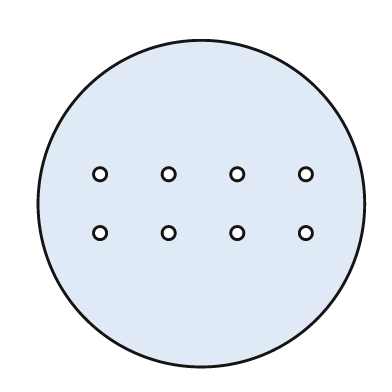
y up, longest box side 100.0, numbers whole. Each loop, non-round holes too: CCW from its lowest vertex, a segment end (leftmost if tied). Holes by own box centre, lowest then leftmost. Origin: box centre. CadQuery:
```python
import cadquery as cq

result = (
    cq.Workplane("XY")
    .moveTo(0.0, 0.0)
    .circle(50.0)
    .moveTo(-31.0, -9.0)
    .circle(2.0)
    .moveTo(-10.0, -9.0)
    .circle(2.0)
    .moveTo(11.0, -9.0)
    .circle(2.0)
    .moveTo(32.0, -9.0)
    .circle(2.0)
    .moveTo(-31.0, 9.0)
    .circle(2.0)
    .moveTo(-10.0, 9.0)
    .circle(2.0)
    .moveTo(11.0, 9.0)
    .circle(2.0)
    .moveTo(32.0, 9.0)
    .circle(2.0)
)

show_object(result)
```